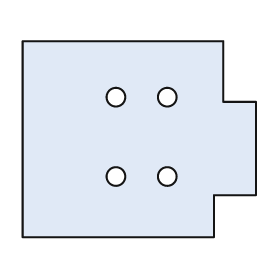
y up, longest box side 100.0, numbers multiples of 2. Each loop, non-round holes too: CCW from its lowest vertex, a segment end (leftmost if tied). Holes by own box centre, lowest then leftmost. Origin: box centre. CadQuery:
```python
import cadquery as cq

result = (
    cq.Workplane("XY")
    .moveTo(-50.0, -42.0)
    .lineTo(32.0, -42.0)
    .lineTo(32.0, -24.0)
    .lineTo(50.0, -24.0)
    .lineTo(50.0, 16.0)
    .lineTo(36.0, 16.0)
    .lineTo(36.0, 42.0)
    .lineTo(-50.0, 42.0)
    .close()
    .moveTo(-10.0, -16.0)
    .circle(4.0)
    .moveTo(12.0, -16.0)
    .circle(4.0)
    .moveTo(-10.0, 18.0)
    .circle(4.0)
    .moveTo(12.0, 18.0)
    .circle(4.0)
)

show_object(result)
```